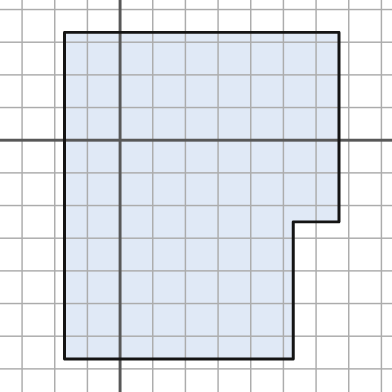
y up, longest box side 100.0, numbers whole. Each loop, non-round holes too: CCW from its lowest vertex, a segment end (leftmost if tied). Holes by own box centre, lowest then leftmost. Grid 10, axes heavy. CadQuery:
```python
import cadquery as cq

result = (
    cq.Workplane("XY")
    .moveTo(-17.0, -67.0)
    .lineTo(53.0, -67.0)
    .lineTo(53.0, -25.0)
    .lineTo(67.0, -25.0)
    .lineTo(67.0, 33.0)
    .lineTo(-17.0, 33.0)
    .close()
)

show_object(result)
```